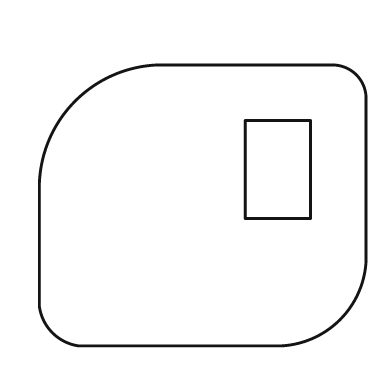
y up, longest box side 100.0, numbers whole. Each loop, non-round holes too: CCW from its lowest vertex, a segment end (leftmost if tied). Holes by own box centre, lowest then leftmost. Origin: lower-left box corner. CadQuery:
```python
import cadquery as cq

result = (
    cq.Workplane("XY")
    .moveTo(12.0, 0.0)
    .lineTo(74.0, 0.0)
    .threePointArc((92.0, 8.0), (100.0, 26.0))
    .lineTo(100.0, 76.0)
    .threePointArc((97.0, 83.0), (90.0, 86.0))
    .lineTo(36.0, 86.0)
    .threePointArc((11.0, 75.0), (0.0, 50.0))
    .lineTo(0.0, 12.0)
    .threePointArc((4.0, 4.0), (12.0, 0.0))
    .close()
    .moveTo(63.0, 39.0)
    .lineTo(83.0, 39.0)
    .lineTo(83.0, 69.0)
    .lineTo(63.0, 69.0)
    .close()
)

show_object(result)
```